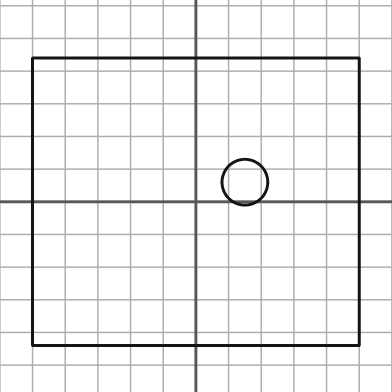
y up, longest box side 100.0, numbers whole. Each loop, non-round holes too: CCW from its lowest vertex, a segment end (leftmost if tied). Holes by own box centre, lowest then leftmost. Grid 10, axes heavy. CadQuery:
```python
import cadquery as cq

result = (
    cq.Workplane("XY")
    .moveTo(-50.0, -44.0)
    .lineTo(50.0, -44.0)
    .lineTo(50.0, 44.0)
    .lineTo(-50.0, 44.0)
    .close()
    .moveTo(15.0, 6.0)
    .circle(7.0)
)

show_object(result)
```